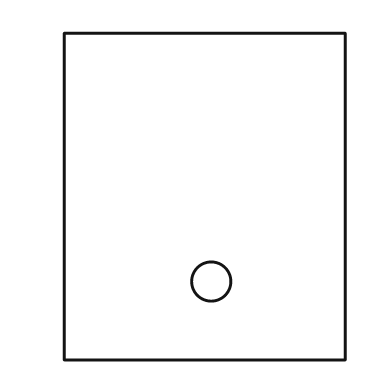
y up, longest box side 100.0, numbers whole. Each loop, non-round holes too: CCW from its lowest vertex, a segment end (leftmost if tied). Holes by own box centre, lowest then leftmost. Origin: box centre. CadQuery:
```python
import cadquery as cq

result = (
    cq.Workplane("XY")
    .moveTo(-43.0, -50.0)
    .lineTo(43.0, -50.0)
    .lineTo(43.0, 50.0)
    .lineTo(-43.0, 50.0)
    .close()
    .moveTo(2.0, -26.0)
    .circle(6.0)
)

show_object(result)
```